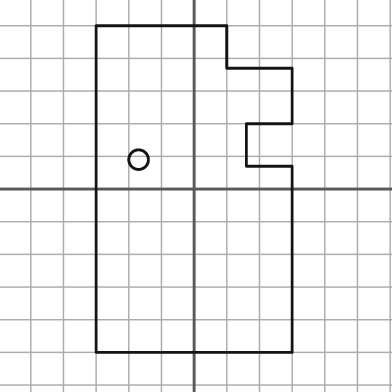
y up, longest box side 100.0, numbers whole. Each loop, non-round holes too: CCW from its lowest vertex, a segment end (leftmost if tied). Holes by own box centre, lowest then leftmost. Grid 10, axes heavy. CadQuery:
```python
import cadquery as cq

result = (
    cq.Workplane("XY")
    .moveTo(-30.0, -50.0)
    .lineTo(30.0, -50.0)
    .lineTo(30.0, 7.0)
    .lineTo(16.0, 7.0)
    .lineTo(16.0, 20.0)
    .lineTo(30.0, 20.0)
    .lineTo(30.0, 37.0)
    .lineTo(10.0, 37.0)
    .lineTo(10.0, 50.0)
    .lineTo(-30.0, 50.0)
    .close()
    .moveTo(-17.0, 9.0)
    .circle(3.0)
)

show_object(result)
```